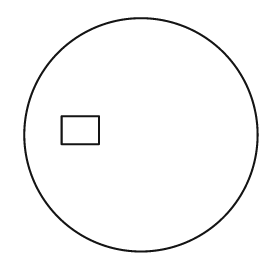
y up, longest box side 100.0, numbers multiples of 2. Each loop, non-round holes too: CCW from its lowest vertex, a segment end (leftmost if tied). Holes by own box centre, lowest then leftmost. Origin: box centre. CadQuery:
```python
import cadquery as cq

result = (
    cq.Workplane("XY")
    .moveTo(0.0, 0.0)
    .circle(50.0)
    .moveTo(-34.0, -4.0)
    .lineTo(-18.0, -4.0)
    .lineTo(-18.0, 8.0)
    .lineTo(-34.0, 8.0)
    .close()
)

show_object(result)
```